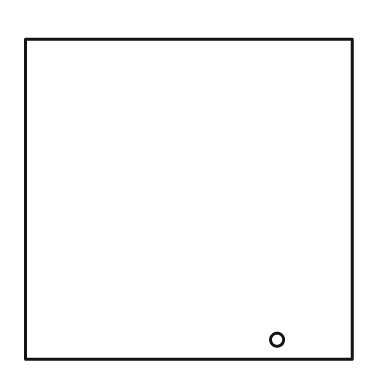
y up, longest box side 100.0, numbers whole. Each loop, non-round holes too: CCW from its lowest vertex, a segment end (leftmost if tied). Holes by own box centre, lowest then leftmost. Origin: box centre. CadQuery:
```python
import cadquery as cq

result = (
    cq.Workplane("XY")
    .moveTo(-50.0, -49.0)
    .lineTo(50.0, -49.0)
    .lineTo(50.0, 49.0)
    .lineTo(-50.0, 49.0)
    .close()
    .moveTo(27.0, -43.0)
    .circle(2.0)
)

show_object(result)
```